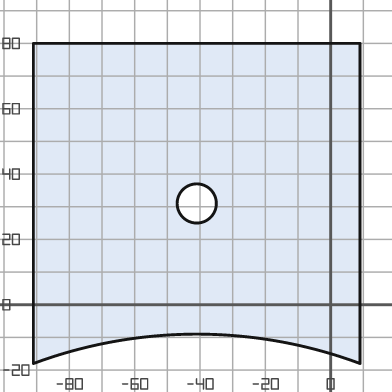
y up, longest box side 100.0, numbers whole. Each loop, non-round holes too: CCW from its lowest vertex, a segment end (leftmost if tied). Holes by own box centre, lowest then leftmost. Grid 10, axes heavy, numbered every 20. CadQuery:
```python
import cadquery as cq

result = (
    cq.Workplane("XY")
    .moveTo(-91.0, -18.0)
    .threePointArc((-41.0, -9.0), (9.0, -18.0))
    .lineTo(9.0, 80.0)
    .lineTo(-91.0, 80.0)
    .close()
    .moveTo(-41.0, 31.0)
    .circle(6.0)
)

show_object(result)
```